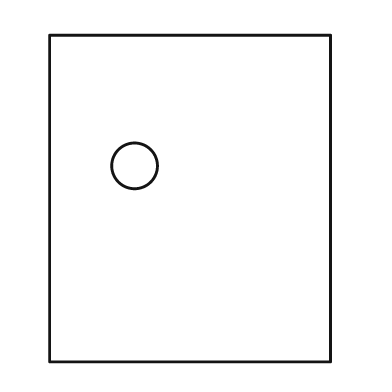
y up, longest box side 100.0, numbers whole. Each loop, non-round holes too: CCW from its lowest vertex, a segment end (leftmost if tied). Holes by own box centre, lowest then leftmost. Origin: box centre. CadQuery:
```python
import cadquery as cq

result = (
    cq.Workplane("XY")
    .moveTo(-43.0, -50.0)
    .lineTo(43.0, -50.0)
    .lineTo(43.0, 50.0)
    .lineTo(-43.0, 50.0)
    .close()
    .moveTo(-17.0, 10.0)
    .circle(7.0)
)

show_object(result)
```